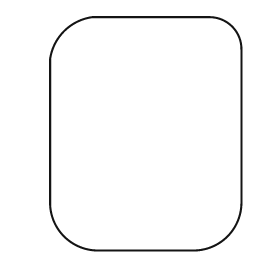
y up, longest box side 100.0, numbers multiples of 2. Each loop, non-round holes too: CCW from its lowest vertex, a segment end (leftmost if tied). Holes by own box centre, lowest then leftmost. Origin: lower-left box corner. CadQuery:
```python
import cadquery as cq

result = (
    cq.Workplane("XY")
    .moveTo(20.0, 0.0)
    .lineTo(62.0, 0.0)
    .threePointArc((76.0, 6.0), (82.0, 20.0))
    .lineTo(82.0, 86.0)
    .threePointArc((78.0, 96.0), (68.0, 100.0))
    .lineTo(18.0, 100.0)
    .threePointArc((6.0, 94.0), (0.0, 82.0))
    .lineTo(0.0, 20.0)
    .threePointArc((6.0, 6.0), (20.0, 0.0))
    .close()
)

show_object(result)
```